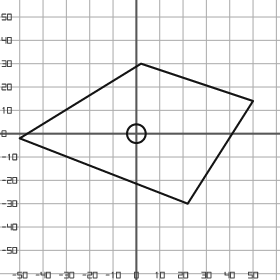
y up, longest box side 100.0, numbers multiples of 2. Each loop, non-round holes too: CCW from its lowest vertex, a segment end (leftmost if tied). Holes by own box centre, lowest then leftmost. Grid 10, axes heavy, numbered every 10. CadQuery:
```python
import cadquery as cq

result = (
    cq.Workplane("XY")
    .moveTo(22.0, -30.0)
    .lineTo(50.0, 14.0)
    .lineTo(2.0, 30.0)
    .lineTo(-50.0, -2.0)
    .close()
    .moveTo(0.0, 0.0)
    .circle(4.0)
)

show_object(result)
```